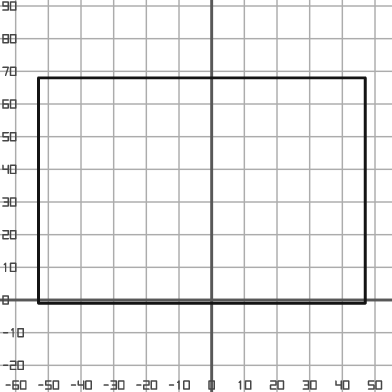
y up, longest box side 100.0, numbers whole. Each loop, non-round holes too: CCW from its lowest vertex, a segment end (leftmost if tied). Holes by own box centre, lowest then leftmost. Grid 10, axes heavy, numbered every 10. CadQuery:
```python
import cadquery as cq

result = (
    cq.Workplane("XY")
    .moveTo(-53.0, -1.0)
    .lineTo(47.0, -1.0)
    .lineTo(47.0, 68.0)
    .lineTo(-53.0, 68.0)
    .close()
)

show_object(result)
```